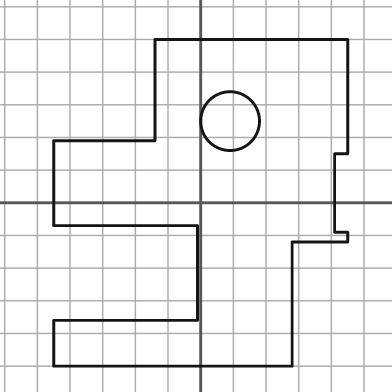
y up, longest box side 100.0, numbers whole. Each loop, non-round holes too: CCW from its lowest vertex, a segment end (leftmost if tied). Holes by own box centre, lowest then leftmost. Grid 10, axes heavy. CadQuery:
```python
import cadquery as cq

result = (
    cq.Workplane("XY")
    .moveTo(-45.0, -50.0)
    .lineTo(28.0, -50.0)
    .lineTo(28.0, -12.0)
    .lineTo(45.0, -12.0)
    .lineTo(45.0, -9.0)
    .lineTo(41.0, -9.0)
    .lineTo(41.0, 15.0)
    .lineTo(45.0, 15.0)
    .lineTo(45.0, 50.0)
    .lineTo(-14.0, 50.0)
    .lineTo(-14.0, 19.0)
    .lineTo(-45.0, 19.0)
    .lineTo(-45.0, -7.0)
    .lineTo(-1.0, -7.0)
    .lineTo(-1.0, -36.0)
    .lineTo(-45.0, -36.0)
    .close()
    .moveTo(9.0, 25.0)
    .circle(9.0)
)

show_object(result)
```